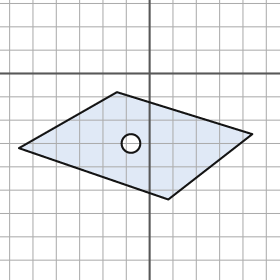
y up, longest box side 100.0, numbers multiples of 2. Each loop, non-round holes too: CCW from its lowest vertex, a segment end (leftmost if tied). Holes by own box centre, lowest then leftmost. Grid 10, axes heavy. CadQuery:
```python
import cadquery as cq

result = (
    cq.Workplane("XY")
    .moveTo(8.0, -54.0)
    .lineTo(44.0, -26.0)
    .lineTo(-14.0, -8.0)
    .lineTo(-56.0, -32.0)
    .close()
    .moveTo(-8.0, -30.0)
    .circle(4.0)
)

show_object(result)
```